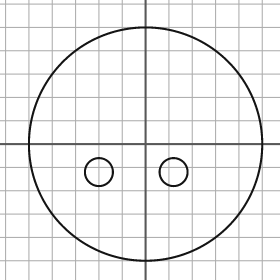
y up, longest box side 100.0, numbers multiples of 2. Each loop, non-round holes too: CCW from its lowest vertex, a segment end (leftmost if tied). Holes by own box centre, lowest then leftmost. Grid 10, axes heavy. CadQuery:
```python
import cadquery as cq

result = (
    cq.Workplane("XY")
    .moveTo(0.0, 0.0)
    .circle(50.0)
    .moveTo(-20.0, -12.0)
    .circle(6.0)
    .moveTo(12.0, -12.0)
    .circle(6.0)
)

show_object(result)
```